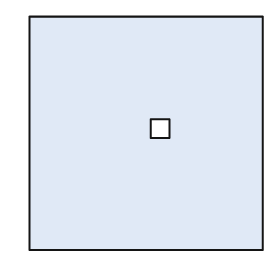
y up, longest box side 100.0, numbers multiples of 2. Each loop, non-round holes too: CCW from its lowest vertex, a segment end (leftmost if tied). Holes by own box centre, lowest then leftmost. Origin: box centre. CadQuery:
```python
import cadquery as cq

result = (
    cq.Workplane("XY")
    .moveTo(-50.0, -50.0)
    .lineTo(50.0, -50.0)
    .lineTo(50.0, 50.0)
    .lineTo(-50.0, 50.0)
    .close()
    .moveTo(2.0, -2.0)
    .lineTo(10.0, -2.0)
    .lineTo(10.0, 6.0)
    .lineTo(2.0, 6.0)
    .close()
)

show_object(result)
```